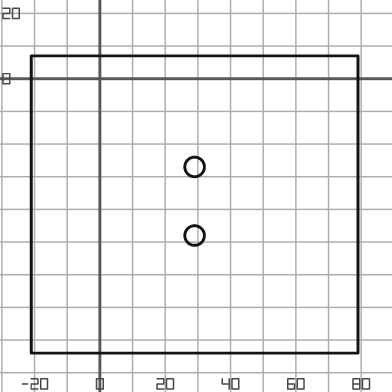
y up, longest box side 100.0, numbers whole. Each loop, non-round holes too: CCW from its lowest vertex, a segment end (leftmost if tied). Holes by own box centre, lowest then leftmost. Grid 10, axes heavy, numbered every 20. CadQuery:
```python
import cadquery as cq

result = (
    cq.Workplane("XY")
    .moveTo(-21.0, -84.0)
    .lineTo(79.0, -84.0)
    .lineTo(79.0, 7.0)
    .lineTo(-21.0, 7.0)
    .close()
    .moveTo(29.0, -48.0)
    .circle(3.0)
    .moveTo(29.0, -27.0)
    .circle(3.0)
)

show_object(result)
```